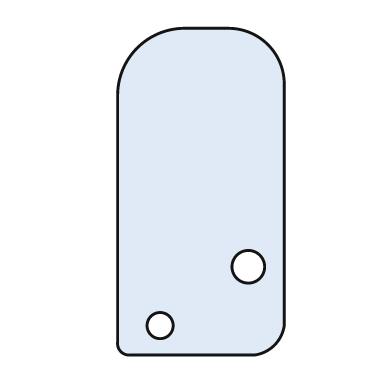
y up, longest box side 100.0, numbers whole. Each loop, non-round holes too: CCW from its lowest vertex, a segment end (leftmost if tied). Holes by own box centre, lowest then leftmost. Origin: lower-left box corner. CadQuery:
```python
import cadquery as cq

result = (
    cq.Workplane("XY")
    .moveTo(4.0, 0.0)
    .lineTo(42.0, 0.0)
    .threePointArc((48.0, 3.0), (51.0, 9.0))
    .lineTo(51.0, 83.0)
    .threePointArc((46.0, 95.0), (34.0, 100.0))
    .lineTo(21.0, 100.0)
    .threePointArc((6.0, 94.0), (0.0, 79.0))
    .lineTo(0.0, 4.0)
    .threePointArc((1.0, 1.0), (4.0, 0.0))
    .close()
    .moveTo(13.0, 9.0)
    .circle(4.0)
    .moveTo(40.0, 27.0)
    .circle(5.0)
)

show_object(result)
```